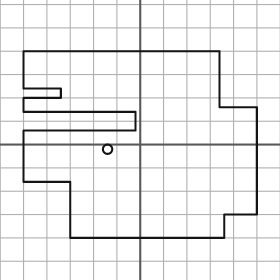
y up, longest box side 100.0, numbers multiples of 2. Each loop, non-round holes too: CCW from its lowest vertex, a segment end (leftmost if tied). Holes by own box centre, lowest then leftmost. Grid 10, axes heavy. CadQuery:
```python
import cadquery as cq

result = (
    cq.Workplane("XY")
    .moveTo(-30.0, -40.0)
    .lineTo(36.0, -40.0)
    .lineTo(36.0, -30.0)
    .lineTo(50.0, -30.0)
    .lineTo(50.0, 16.0)
    .lineTo(34.0, 16.0)
    .lineTo(34.0, 40.0)
    .lineTo(-50.0, 40.0)
    .lineTo(-50.0, 24.0)
    .lineTo(-34.0, 24.0)
    .lineTo(-34.0, 20.0)
    .lineTo(-50.0, 20.0)
    .lineTo(-50.0, 14.0)
    .lineTo(-2.0, 14.0)
    .lineTo(-2.0, 6.0)
    .lineTo(-50.0, 6.0)
    .lineTo(-50.0, -16.0)
    .lineTo(-30.0, -16.0)
    .close()
    .moveTo(-14.0, -2.0)
    .circle(2.0)
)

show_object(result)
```